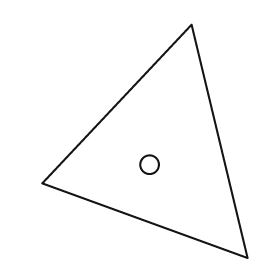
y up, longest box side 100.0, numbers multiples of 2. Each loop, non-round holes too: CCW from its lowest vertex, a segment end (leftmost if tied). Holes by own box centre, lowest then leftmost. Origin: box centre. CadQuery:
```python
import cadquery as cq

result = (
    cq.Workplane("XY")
    .moveTo(44.0, -50.0)
    .lineTo(20.0, 50.0)
    .lineTo(-44.0, -18.0)
    .close()
    .moveTo(2.0, -10.0)
    .circle(4.0)
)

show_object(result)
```